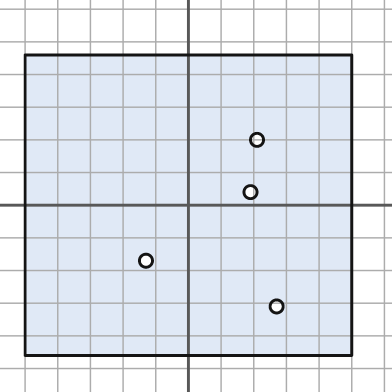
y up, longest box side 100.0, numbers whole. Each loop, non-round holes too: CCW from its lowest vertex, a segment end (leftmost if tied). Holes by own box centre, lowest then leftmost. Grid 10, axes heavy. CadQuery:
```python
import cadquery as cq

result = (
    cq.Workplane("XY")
    .moveTo(-50.0, -46.0)
    .lineTo(50.0, -46.0)
    .lineTo(50.0, 46.0)
    .lineTo(-50.0, 46.0)
    .close()
    .moveTo(27.0, -31.0)
    .circle(2.0)
    .moveTo(-13.0, -17.0)
    .circle(2.0)
    .moveTo(19.0, 4.0)
    .circle(2.0)
    .moveTo(21.0, 20.0)
    .circle(2.0)
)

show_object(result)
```